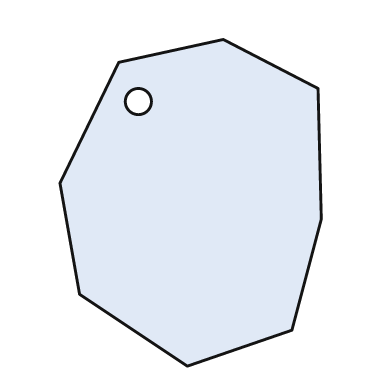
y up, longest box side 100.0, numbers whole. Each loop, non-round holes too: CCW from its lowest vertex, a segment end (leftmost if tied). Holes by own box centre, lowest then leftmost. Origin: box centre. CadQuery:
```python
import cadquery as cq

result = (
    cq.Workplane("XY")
    .moveTo(-1.0, -50.0)
    .lineTo(31.0, -39.0)
    .lineTo(40.0, -5.0)
    .lineTo(39.0, 35.0)
    .lineTo(10.0, 50.0)
    .lineTo(-22.0, 43.0)
    .lineTo(-40.0, 6.0)
    .lineTo(-34.0, -28.0)
    .close()
    .moveTo(-16.0, 31.0)
    .circle(4.0)
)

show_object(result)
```